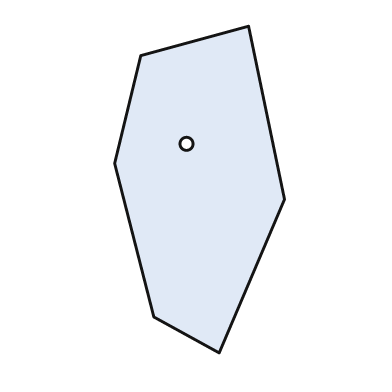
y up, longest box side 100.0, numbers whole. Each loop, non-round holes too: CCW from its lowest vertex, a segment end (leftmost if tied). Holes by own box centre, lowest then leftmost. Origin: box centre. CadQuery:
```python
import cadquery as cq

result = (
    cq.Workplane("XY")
    .moveTo(6.0, -50.0)
    .lineTo(26.0, -3.0)
    .lineTo(15.0, 50.0)
    .lineTo(-18.0, 41.0)
    .lineTo(-26.0, 8.0)
    .lineTo(-14.0, -39.0)
    .close()
    .moveTo(-4.0, 14.0)
    .circle(2.0)
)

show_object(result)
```